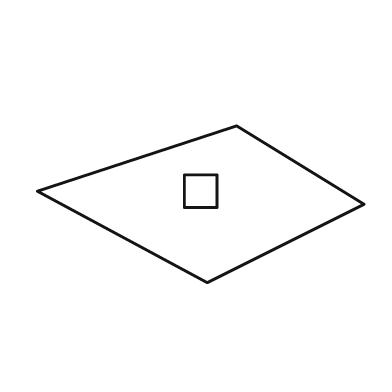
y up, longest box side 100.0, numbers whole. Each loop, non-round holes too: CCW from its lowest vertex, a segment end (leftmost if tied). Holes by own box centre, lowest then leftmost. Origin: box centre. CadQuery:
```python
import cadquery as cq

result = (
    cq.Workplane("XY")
    .moveTo(2.0, -24.0)
    .lineTo(50.0, 0.0)
    .lineTo(11.0, 24.0)
    .lineTo(-50.0, 4.0)
    .close()
    .moveTo(-5.0, -1.0)
    .lineTo(5.0, -1.0)
    .lineTo(5.0, 9.0)
    .lineTo(-5.0, 9.0)
    .close()
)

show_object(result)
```